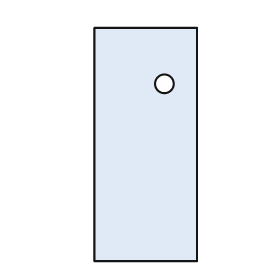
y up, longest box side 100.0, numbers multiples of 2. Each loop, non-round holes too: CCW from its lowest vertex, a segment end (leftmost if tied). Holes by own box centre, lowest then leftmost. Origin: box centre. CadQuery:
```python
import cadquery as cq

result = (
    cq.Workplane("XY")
    .moveTo(-22.0, -50.0)
    .lineTo(22.0, -50.0)
    .lineTo(22.0, 50.0)
    .lineTo(-22.0, 50.0)
    .close()
    .moveTo(8.0, 26.0)
    .circle(4.0)
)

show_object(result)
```